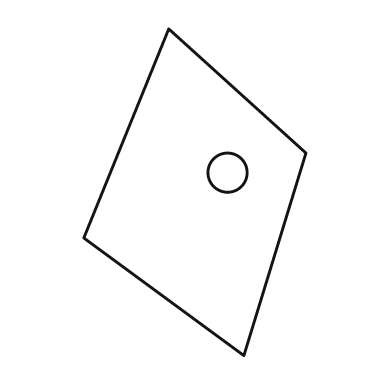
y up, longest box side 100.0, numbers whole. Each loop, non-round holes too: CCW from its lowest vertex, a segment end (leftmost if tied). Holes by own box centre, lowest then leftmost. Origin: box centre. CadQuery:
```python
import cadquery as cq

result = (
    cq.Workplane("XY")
    .moveTo(15.0, -50.0)
    .lineTo(34.0, 12.0)
    .lineTo(-8.0, 50.0)
    .lineTo(-34.0, -14.0)
    .close()
    .moveTo(10.0, 6.0)
    .circle(6.0)
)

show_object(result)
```